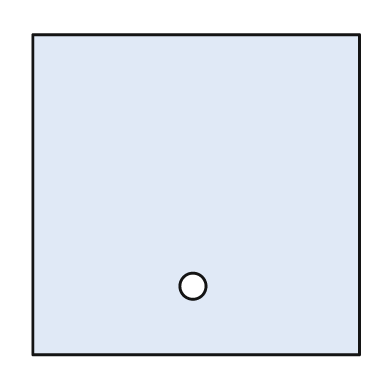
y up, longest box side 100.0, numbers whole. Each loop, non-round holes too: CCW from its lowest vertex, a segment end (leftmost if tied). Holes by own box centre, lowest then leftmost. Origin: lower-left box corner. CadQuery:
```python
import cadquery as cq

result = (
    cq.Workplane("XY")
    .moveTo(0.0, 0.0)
    .lineTo(100.0, 0.0)
    .lineTo(100.0, 98.0)
    .lineTo(0.0, 98.0)
    .close()
    .moveTo(49.0, 21.0)
    .circle(4.0)
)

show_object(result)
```